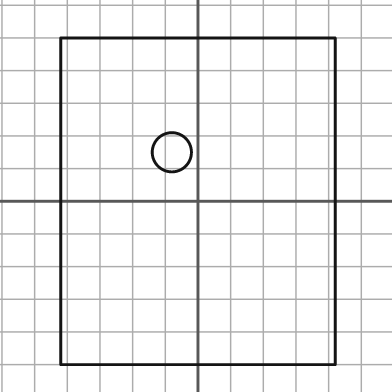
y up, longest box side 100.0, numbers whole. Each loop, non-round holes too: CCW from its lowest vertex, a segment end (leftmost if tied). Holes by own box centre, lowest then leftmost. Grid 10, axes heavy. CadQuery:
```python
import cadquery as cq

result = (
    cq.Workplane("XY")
    .moveTo(-42.0, -50.0)
    .lineTo(42.0, -50.0)
    .lineTo(42.0, 50.0)
    .lineTo(-42.0, 50.0)
    .close()
    .moveTo(-8.0, 15.0)
    .circle(6.0)
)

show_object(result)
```